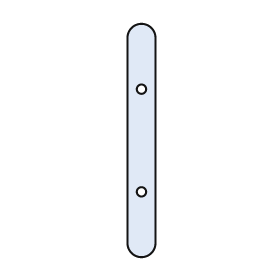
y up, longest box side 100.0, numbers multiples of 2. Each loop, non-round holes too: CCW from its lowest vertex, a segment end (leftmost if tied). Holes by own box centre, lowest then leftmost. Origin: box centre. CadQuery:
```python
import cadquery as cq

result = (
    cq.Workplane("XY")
    .moveTo(-6.0, -44.0)
    .threePointArc((0.0, -50.0), (6.0, -44.0))
    .lineTo(6.0, 44.0)
    .threePointArc((0.0, 50.0), (-6.0, 44.0))
    .close()
    .moveTo(0.0, -22.0)
    .circle(2.0)
    .moveTo(0.0, 22.0)
    .circle(2.0)
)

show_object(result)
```